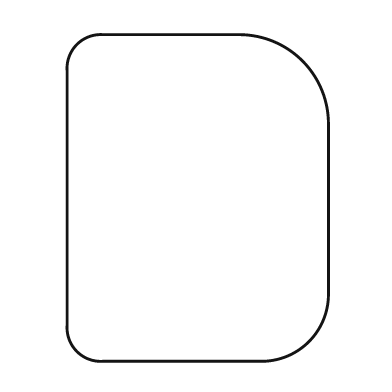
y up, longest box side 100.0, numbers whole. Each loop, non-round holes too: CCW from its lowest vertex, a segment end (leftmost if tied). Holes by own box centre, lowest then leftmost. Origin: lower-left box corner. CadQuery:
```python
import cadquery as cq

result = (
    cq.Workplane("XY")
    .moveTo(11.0, 0.0)
    .lineTo(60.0, 0.0)
    .threePointArc((74.0, 6.0), (80.0, 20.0))
    .lineTo(80.0, 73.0)
    .threePointArc((72.0, 92.0), (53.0, 100.0))
    .lineTo(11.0, 100.0)
    .threePointArc((3.0, 97.0), (0.0, 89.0))
    .lineTo(0.0, 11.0)
    .threePointArc((3.0, 3.0), (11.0, 0.0))
    .close()
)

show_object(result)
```